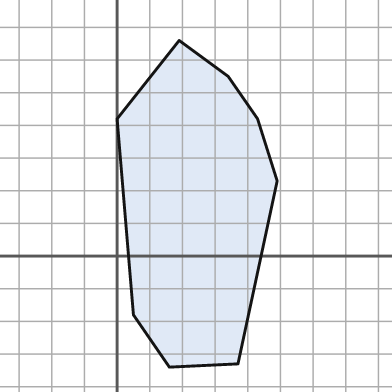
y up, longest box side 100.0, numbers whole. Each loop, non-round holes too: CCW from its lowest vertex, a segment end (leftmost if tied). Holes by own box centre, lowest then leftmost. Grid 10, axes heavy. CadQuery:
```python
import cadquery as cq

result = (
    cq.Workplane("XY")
    .moveTo(16.0, -34.0)
    .lineTo(37.0, -33.0)
    .lineTo(49.0, 23.0)
    .lineTo(43.0, 42.0)
    .lineTo(34.0, 55.0)
    .lineTo(19.0, 66.0)
    .lineTo(0.0, 42.0)
    .lineTo(5.0, -18.0)
    .close()
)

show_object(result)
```